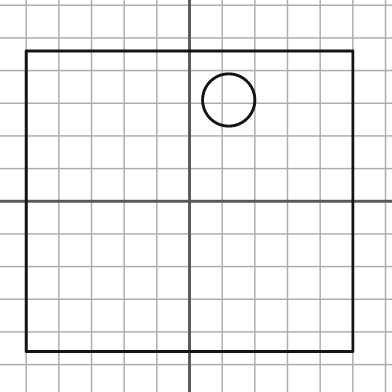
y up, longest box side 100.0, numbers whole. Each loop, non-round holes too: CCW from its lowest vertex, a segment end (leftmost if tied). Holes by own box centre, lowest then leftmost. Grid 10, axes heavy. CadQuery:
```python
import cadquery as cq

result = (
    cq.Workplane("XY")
    .moveTo(-50.0, -46.0)
    .lineTo(50.0, -46.0)
    .lineTo(50.0, 46.0)
    .lineTo(-50.0, 46.0)
    .close()
    .moveTo(12.0, 31.0)
    .circle(8.0)
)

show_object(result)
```